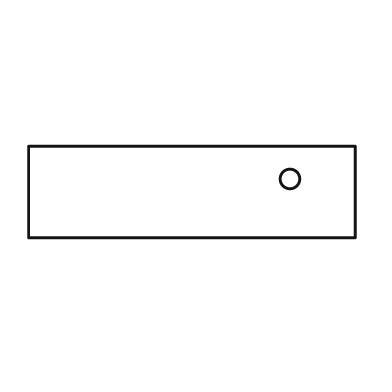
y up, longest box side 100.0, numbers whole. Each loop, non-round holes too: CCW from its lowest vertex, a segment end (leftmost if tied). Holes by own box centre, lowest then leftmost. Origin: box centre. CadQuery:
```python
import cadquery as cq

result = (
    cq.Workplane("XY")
    .moveTo(-50.0, -14.0)
    .lineTo(50.0, -14.0)
    .lineTo(50.0, 14.0)
    .lineTo(-50.0, 14.0)
    .close()
    .moveTo(30.0, 4.0)
    .circle(3.0)
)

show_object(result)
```